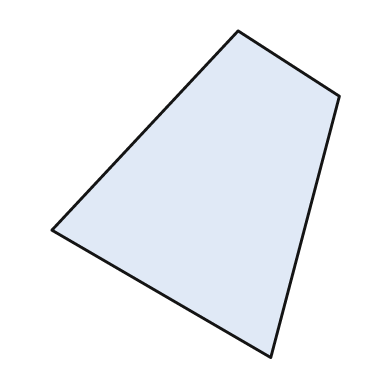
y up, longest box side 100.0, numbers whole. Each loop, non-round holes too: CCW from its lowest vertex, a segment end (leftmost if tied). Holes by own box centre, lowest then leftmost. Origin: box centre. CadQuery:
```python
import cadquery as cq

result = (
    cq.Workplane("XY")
    .moveTo(23.0, -50.0)
    .lineTo(44.0, 30.0)
    .lineTo(13.0, 50.0)
    .lineTo(-44.0, -11.0)
    .close()
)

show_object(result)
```